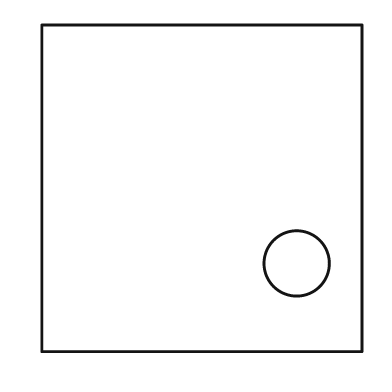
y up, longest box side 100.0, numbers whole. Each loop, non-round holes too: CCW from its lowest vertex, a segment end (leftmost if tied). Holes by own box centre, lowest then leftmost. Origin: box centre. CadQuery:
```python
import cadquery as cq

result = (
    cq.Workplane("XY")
    .moveTo(-49.0, -50.0)
    .lineTo(49.0, -50.0)
    .lineTo(49.0, 50.0)
    .lineTo(-49.0, 50.0)
    .close()
    .moveTo(29.0, -23.0)
    .circle(10.0)
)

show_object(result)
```